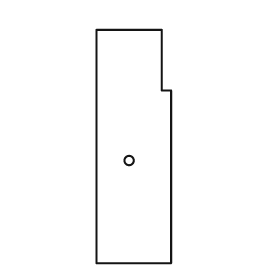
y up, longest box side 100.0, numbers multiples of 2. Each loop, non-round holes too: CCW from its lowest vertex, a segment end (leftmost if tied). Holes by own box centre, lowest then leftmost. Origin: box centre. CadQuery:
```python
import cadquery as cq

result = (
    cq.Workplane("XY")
    .moveTo(-16.0, -50.0)
    .lineTo(16.0, -50.0)
    .lineTo(16.0, 24.0)
    .lineTo(12.0, 24.0)
    .lineTo(12.0, 50.0)
    .lineTo(-16.0, 50.0)
    .close()
    .moveTo(-2.0, -6.0)
    .circle(2.0)
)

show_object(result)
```